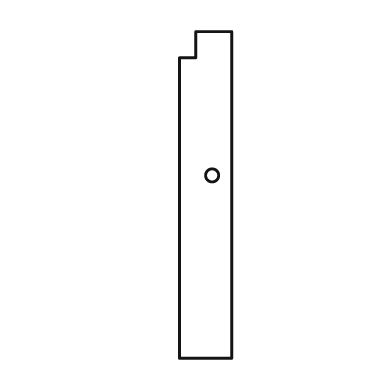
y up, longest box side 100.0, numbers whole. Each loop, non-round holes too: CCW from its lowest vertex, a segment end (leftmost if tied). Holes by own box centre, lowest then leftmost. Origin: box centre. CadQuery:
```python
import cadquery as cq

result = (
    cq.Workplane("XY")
    .moveTo(-8.0, -50.0)
    .lineTo(8.0, -50.0)
    .lineTo(8.0, 50.0)
    .lineTo(-3.0, 50.0)
    .lineTo(-3.0, 42.0)
    .lineTo(-8.0, 42.0)
    .close()
    .moveTo(2.0, 6.0)
    .circle(2.0)
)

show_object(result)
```